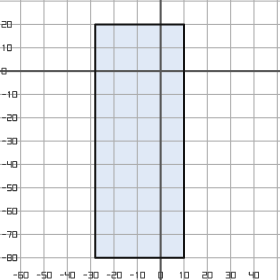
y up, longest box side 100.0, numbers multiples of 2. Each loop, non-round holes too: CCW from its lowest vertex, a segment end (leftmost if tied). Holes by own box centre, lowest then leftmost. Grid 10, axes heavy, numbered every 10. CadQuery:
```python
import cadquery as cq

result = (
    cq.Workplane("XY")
    .moveTo(-28.0, -80.0)
    .lineTo(10.0, -80.0)
    .lineTo(10.0, 20.0)
    .lineTo(-28.0, 20.0)
    .close()
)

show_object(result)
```